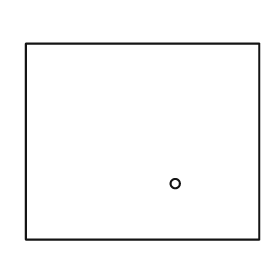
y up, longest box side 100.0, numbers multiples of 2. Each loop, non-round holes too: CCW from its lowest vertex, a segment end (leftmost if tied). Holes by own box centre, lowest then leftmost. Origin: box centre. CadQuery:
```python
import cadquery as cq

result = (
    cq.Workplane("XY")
    .moveTo(-50.0, -42.0)
    .lineTo(50.0, -42.0)
    .lineTo(50.0, 42.0)
    .lineTo(-50.0, 42.0)
    .close()
    .moveTo(14.0, -18.0)
    .circle(2.0)
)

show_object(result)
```